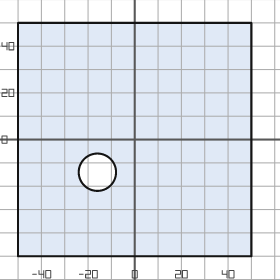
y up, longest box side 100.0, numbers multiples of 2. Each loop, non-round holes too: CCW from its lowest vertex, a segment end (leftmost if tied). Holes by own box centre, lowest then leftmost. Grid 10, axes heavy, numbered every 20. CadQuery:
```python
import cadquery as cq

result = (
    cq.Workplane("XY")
    .moveTo(-50.0, -50.0)
    .lineTo(50.0, -50.0)
    .lineTo(50.0, 50.0)
    .lineTo(-50.0, 50.0)
    .close()
    .moveTo(-16.0, -14.0)
    .circle(8.0)
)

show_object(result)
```